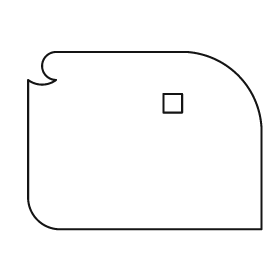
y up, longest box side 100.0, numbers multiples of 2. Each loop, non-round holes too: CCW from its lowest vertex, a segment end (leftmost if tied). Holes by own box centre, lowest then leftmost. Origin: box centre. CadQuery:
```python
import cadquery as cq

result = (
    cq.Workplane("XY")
    .moveTo(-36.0, -38.0)
    .lineTo(50.0, -38.0)
    .lineTo(50.0, 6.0)
    .threePointArc((40.0, 28.0), (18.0, 38.0))
    .lineTo(-38.0, 38.0)
    .threePointArc((-44.0, 32.0), (-38.0, 26.0))
    .threePointArc((-44.0, 24.0), (-50.0, 26.0))
    .lineTo(-50.0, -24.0)
    .threePointArc((-46.0, -34.0), (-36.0, -38.0))
    .close()
    .moveTo(8.0, 12.0)
    .lineTo(16.0, 12.0)
    .lineTo(16.0, 20.0)
    .lineTo(8.0, 20.0)
    .close()
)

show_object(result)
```